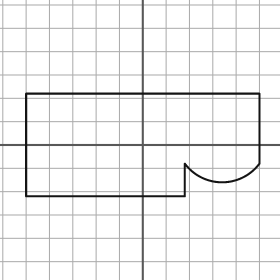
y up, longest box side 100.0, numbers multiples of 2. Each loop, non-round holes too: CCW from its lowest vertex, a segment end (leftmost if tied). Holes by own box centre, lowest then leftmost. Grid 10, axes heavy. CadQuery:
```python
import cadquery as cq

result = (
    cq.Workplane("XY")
    .moveTo(-50.0, -22.0)
    .lineTo(18.0, -22.0)
    .lineTo(18.0, -8.0)
    .threePointArc((34.0, -16.0), (50.0, -8.0))
    .lineTo(50.0, 22.0)
    .lineTo(-50.0, 22.0)
    .close()
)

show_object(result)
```